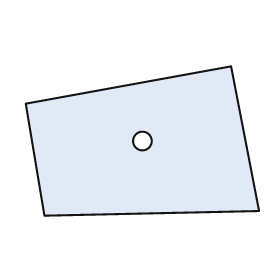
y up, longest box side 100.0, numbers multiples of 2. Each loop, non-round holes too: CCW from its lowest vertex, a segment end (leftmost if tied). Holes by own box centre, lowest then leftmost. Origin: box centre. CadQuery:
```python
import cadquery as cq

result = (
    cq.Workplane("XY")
    .moveTo(-42.0, -32.0)
    .lineTo(50.0, -30.0)
    .lineTo(38.0, 32.0)
    .lineTo(-50.0, 16.0)
    .close()
    .moveTo(0.0, 0.0)
    .circle(4.0)
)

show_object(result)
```